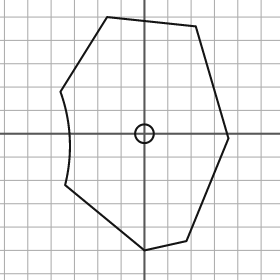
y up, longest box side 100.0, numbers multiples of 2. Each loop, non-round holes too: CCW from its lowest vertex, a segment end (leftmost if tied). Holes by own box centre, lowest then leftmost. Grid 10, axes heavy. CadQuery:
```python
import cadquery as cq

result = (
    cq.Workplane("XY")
    .moveTo(0.0, -50.0)
    .lineTo(18.0, -46.0)
    .lineTo(36.0, -2.0)
    .lineTo(22.0, 46.0)
    .lineTo(-16.0, 50.0)
    .lineTo(-36.0, 18.0)
    .threePointArc((-32.0, -2.0), (-34.0, -22.0))
    .close()
    .moveTo(0.0, 0.0)
    .circle(4.0)
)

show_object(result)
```